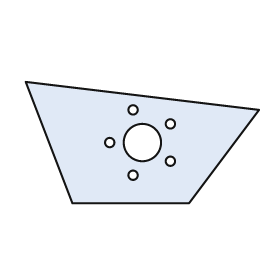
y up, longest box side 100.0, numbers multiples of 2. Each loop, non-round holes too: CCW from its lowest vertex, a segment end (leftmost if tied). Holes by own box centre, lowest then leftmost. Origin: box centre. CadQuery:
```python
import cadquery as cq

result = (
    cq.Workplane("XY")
    .moveTo(-30.0, -26.0)
    .lineTo(20.0, -26.0)
    .lineTo(50.0, 14.0)
    .lineTo(-50.0, 26.0)
    .close()
    .moveTo(-4.0, -14.0)
    .circle(2.0)
    .moveTo(12.0, -8.0)
    .circle(2.0)
    .moveTo(-14.0, 0.0)
    .circle(2.0)
    .moveTo(0.0, 0.0)
    .circle(8.0)
    .moveTo(12.0, 8.0)
    .circle(2.0)
    .moveTo(-4.0, 14.0)
    .circle(2.0)
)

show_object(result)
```